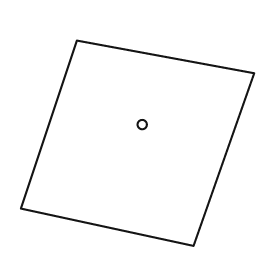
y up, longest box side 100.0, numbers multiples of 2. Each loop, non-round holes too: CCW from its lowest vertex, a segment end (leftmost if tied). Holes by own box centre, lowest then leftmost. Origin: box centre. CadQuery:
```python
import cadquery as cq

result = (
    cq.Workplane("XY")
    .moveTo(24.0, -44.0)
    .lineTo(50.0, 30.0)
    .lineTo(-26.0, 44.0)
    .lineTo(-50.0, -28.0)
    .close()
    .moveTo(2.0, 8.0)
    .circle(2.0)
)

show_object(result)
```